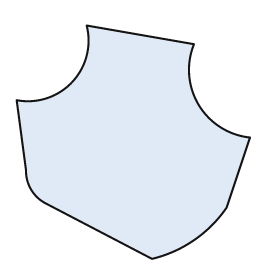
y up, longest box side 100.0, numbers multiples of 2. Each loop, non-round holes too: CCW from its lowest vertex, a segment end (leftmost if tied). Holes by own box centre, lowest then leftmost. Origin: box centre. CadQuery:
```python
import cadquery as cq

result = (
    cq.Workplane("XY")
    .moveTo(8.0, -50.0)
    .threePointArc((26.0, -42.0), (40.0, -28.0))
    .lineTo(50.0, 2.0)
    .threePointArc((28.0, 16.0), (26.0, 42.0))
    .lineTo(-20.0, 50.0)
    .threePointArc((-26.0, 26.0), (-50.0, 18.0))
    .lineTo(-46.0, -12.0)
    .threePointArc((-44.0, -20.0), (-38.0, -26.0))
    .close()
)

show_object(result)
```